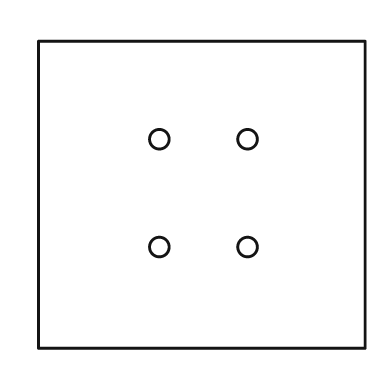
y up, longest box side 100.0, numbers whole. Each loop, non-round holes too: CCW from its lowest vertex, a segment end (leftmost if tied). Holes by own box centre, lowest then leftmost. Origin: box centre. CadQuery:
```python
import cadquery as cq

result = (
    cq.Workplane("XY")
    .moveTo(-50.0, -47.0)
    .lineTo(50.0, -47.0)
    .lineTo(50.0, 47.0)
    .lineTo(-50.0, 47.0)
    .close()
    .moveTo(-13.0, -16.0)
    .circle(3.0)
    .moveTo(14.0, -16.0)
    .circle(3.0)
    .moveTo(-13.0, 17.0)
    .circle(3.0)
    .moveTo(14.0, 17.0)
    .circle(3.0)
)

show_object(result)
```